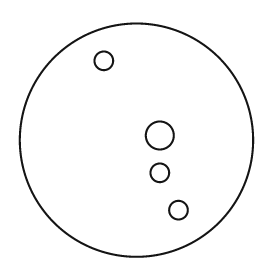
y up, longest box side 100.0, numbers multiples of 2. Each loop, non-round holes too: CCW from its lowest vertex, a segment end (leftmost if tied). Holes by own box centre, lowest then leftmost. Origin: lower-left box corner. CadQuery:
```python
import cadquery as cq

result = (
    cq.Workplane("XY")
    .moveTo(50.0, 50.0)
    .circle(50.0)
    .moveTo(68.0, 20.0)
    .circle(4.0)
    .moveTo(60.0, 36.0)
    .circle(4.0)
    .moveTo(60.0, 52.0)
    .circle(6.0)
    .moveTo(36.0, 84.0)
    .circle(4.0)
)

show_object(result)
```